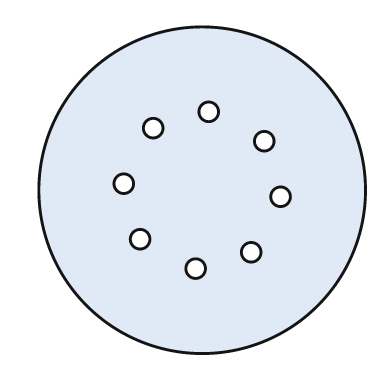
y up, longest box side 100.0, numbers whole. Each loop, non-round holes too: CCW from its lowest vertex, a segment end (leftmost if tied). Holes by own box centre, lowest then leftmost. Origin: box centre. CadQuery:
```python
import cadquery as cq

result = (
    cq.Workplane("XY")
    .moveTo(0.0, 0.0)
    .circle(50.0)
    .moveTo(-2.0, -24.0)
    .circle(3.0)
    .moveTo(15.0, -19.0)
    .circle(3.0)
    .moveTo(-19.0, -15.0)
    .circle(3.0)
    .moveTo(24.0, -2.0)
    .circle(3.0)
    .moveTo(-24.0, 2.0)
    .circle(3.0)
    .moveTo(19.0, 15.0)
    .circle(3.0)
    .moveTo(-15.0, 19.0)
    .circle(3.0)
    .moveTo(2.0, 24.0)
    .circle(3.0)
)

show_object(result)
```